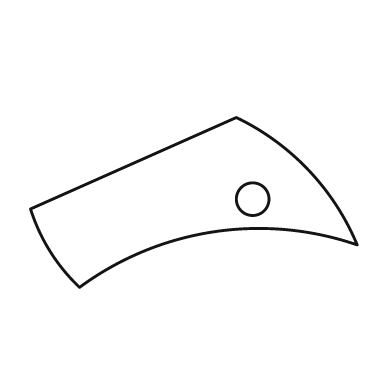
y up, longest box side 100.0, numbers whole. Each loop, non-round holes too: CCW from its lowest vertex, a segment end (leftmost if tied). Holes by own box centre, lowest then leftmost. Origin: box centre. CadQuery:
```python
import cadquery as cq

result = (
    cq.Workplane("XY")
    .moveTo(-35.0, -26.0)
    .threePointArc((6.0, -9.0), (50.0, -13.0))
    .threePointArc((35.0, 10.0), (13.0, 26.0))
    .lineTo(-50.0, -2.0)
    .threePointArc((-44.0, -15.0), (-35.0, -26.0))
    .close()
    .moveTo(18.0, 1.0)
    .circle(5.0)
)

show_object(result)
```